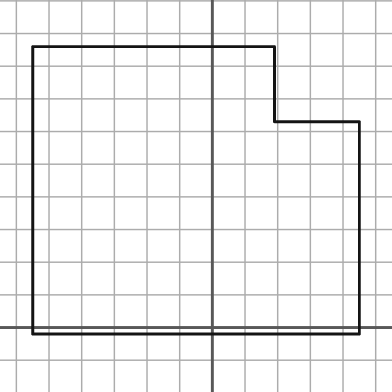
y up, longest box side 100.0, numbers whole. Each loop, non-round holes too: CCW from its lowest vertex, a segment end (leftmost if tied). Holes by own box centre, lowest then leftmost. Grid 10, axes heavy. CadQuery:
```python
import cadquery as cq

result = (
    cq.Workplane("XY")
    .moveTo(-55.0, -2.0)
    .lineTo(45.0, -2.0)
    .lineTo(45.0, 63.0)
    .lineTo(19.0, 63.0)
    .lineTo(19.0, 86.0)
    .lineTo(-55.0, 86.0)
    .close()
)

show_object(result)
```